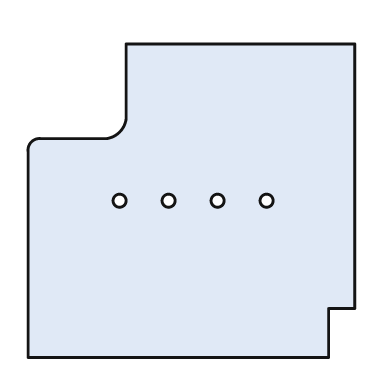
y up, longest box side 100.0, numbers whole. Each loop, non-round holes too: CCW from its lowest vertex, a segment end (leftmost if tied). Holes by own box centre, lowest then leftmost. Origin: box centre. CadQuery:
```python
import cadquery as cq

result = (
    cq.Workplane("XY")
    .moveTo(-50.0, -48.0)
    .lineTo(42.0, -48.0)
    .lineTo(42.0, -33.0)
    .lineTo(50.0, -33.0)
    .lineTo(50.0, 48.0)
    .lineTo(-20.0, 48.0)
    .lineTo(-20.0, 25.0)
    .threePointArc((-22.0, 21.0), (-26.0, 19.0))
    .lineTo(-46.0, 19.0)
    .threePointArc((-49.0, 18.0), (-50.0, 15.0))
    .close()
    .moveTo(-22.0, 0.0)
    .circle(2.0)
    .moveTo(-7.0, 0.0)
    .circle(2.0)
    .moveTo(8.0, 0.0)
    .circle(2.0)
    .moveTo(23.0, 0.0)
    .circle(2.0)
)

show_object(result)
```